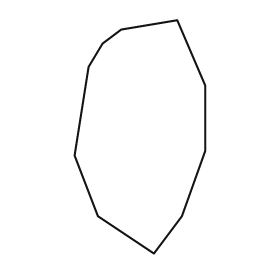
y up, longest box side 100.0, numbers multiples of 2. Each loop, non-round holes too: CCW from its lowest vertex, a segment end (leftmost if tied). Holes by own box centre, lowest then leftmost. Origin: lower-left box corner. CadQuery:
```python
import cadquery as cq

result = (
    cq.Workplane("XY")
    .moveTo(34.0, 0.0)
    .lineTo(46.0, 16.0)
    .lineTo(56.0, 44.0)
    .lineTo(56.0, 72.0)
    .lineTo(44.0, 100.0)
    .lineTo(20.0, 96.0)
    .lineTo(12.0, 90.0)
    .lineTo(6.0, 80.0)
    .lineTo(0.0, 42.0)
    .lineTo(10.0, 16.0)
    .close()
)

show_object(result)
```